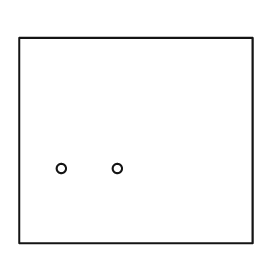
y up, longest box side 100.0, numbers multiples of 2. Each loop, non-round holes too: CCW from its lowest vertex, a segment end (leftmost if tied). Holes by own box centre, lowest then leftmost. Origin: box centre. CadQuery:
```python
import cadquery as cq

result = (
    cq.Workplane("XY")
    .moveTo(-50.0, -44.0)
    .lineTo(50.0, -44.0)
    .lineTo(50.0, 44.0)
    .lineTo(-50.0, 44.0)
    .close()
    .moveTo(-32.0, -12.0)
    .circle(2.0)
    .moveTo(-8.0, -12.0)
    .circle(2.0)
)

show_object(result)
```